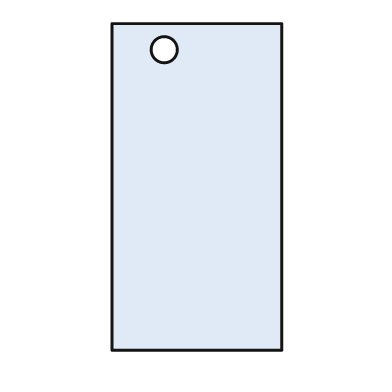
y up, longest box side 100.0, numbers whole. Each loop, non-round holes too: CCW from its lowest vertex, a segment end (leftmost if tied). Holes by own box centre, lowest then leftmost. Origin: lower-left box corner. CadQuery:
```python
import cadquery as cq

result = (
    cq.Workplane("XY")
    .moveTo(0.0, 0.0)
    .lineTo(52.0, 0.0)
    .lineTo(52.0, 100.0)
    .lineTo(0.0, 100.0)
    .close()
    .moveTo(16.0, 92.0)
    .circle(4.0)
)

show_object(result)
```